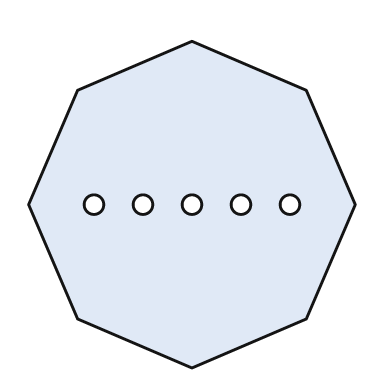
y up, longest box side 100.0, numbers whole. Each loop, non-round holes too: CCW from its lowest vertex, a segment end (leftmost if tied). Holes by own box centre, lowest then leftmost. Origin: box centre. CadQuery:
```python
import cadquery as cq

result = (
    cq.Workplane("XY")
    .moveTo(0.0, -50.0)
    .lineTo(35.0, -35.0)
    .lineTo(50.0, 0.0)
    .lineTo(35.0, 35.0)
    .lineTo(0.0, 50.0)
    .lineTo(-35.0, 35.0)
    .lineTo(-50.0, 0.0)
    .lineTo(-35.0, -35.0)
    .close()
    .moveTo(-30.0, 0.0)
    .circle(3.0)
    .moveTo(-15.0, 0.0)
    .circle(3.0)
    .moveTo(0.0, 0.0)
    .circle(3.0)
    .moveTo(15.0, 0.0)
    .circle(3.0)
    .moveTo(30.0, 0.0)
    .circle(3.0)
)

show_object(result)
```